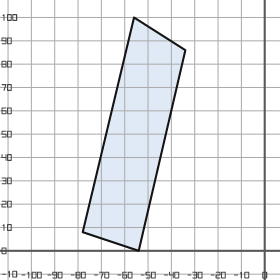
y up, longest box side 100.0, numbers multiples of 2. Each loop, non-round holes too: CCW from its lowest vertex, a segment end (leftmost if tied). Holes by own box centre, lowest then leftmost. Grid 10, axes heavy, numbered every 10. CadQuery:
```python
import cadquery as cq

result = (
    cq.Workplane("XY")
    .moveTo(-54.0, 0.0)
    .lineTo(-34.0, 86.0)
    .lineTo(-56.0, 100.0)
    .lineTo(-78.0, 8.0)
    .close()
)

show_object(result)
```